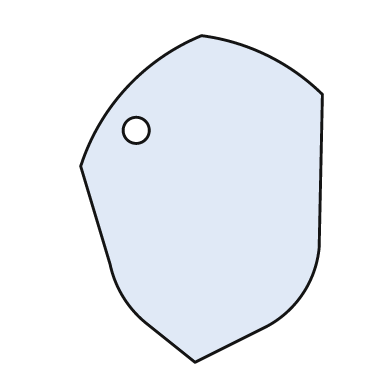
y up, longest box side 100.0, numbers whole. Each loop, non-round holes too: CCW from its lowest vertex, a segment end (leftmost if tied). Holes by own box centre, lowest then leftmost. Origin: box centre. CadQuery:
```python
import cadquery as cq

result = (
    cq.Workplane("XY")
    .moveTo(-2.0, -50.0)
    .lineTo(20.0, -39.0)
    .threePointArc((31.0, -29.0), (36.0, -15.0))
    .lineTo(37.0, 32.0)
    .threePointArc((20.0, 44.0), (0.0, 50.0))
    .threePointArc((-23.0, 34.0), (-37.0, 10.0))
    .lineTo(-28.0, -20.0)
    .threePointArc((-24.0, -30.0), (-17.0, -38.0))
    .close()
    .moveTo(-20.0, 21.0)
    .circle(4.0)
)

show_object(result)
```